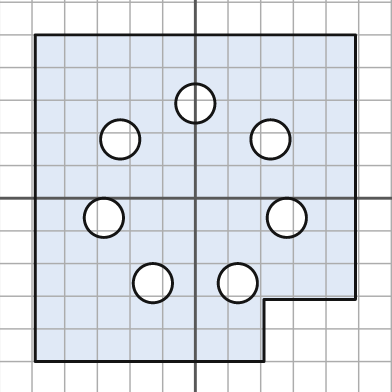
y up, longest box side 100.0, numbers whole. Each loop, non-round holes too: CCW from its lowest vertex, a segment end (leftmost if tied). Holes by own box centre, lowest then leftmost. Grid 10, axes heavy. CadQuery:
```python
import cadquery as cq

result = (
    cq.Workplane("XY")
    .moveTo(-49.0, -50.0)
    .lineTo(21.0, -50.0)
    .lineTo(21.0, -31.0)
    .lineTo(49.0, -31.0)
    .lineTo(49.0, 50.0)
    .lineTo(-49.0, 50.0)
    .close()
    .moveTo(-13.0, -26.0)
    .circle(6.0)
    .moveTo(13.0, -26.0)
    .circle(6.0)
    .moveTo(-28.0, -6.0)
    .circle(6.0)
    .moveTo(28.0, -6.0)
    .circle(6.0)
    .moveTo(-23.0, 18.0)
    .circle(6.0)
    .moveTo(23.0, 18.0)
    .circle(6.0)
    .moveTo(0.0, 29.0)
    .circle(6.0)
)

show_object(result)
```